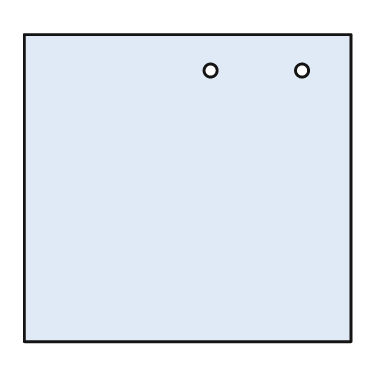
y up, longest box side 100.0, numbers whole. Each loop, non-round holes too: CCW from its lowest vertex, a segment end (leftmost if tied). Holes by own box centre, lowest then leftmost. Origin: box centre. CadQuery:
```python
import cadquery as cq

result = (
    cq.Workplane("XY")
    .moveTo(-50.0, -47.0)
    .lineTo(50.0, -47.0)
    .lineTo(50.0, 47.0)
    .lineTo(-50.0, 47.0)
    .close()
    .moveTo(7.0, 36.0)
    .circle(2.0)
    .moveTo(35.0, 36.0)
    .circle(2.0)
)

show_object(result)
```